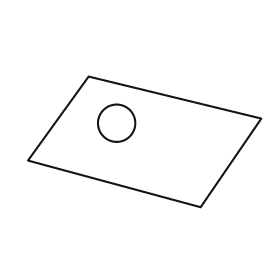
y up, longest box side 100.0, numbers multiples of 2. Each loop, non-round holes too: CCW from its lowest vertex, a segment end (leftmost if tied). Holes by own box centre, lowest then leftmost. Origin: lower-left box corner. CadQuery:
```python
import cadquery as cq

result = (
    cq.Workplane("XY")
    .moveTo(74.0, 0.0)
    .lineTo(100.0, 38.0)
    .lineTo(26.0, 56.0)
    .lineTo(0.0, 20.0)
    .close()
    .moveTo(38.0, 36.0)
    .circle(8.0)
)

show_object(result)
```